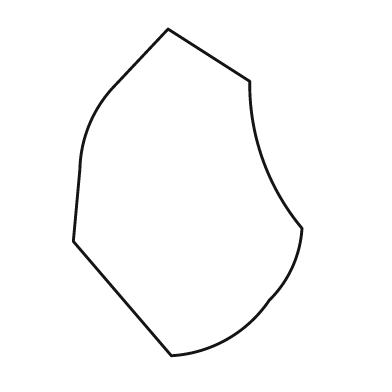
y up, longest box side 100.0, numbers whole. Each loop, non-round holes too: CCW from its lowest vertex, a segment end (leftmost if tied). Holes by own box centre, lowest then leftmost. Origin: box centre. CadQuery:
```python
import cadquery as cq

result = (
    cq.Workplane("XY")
    .moveTo(-5.0, -50.0)
    .threePointArc((12.0, -45.0), (25.0, -33.0))
    .threePointArc((32.0, -23.0), (35.0, -11.0))
    .threePointArc((23.0, 10.0), (19.0, 34.0))
    .lineTo(-6.0, 50.0)
    .lineTo(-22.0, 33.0)
    .threePointArc((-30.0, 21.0), (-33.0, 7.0))
    .lineTo(-35.0, -15.0)
    .close()
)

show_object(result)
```